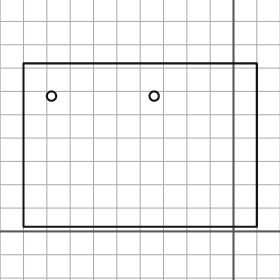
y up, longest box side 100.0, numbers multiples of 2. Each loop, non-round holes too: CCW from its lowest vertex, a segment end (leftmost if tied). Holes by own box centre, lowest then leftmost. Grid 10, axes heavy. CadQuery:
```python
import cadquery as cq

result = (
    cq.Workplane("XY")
    .moveTo(-90.0, 2.0)
    .lineTo(10.0, 2.0)
    .lineTo(10.0, 72.0)
    .lineTo(-90.0, 72.0)
    .close()
    .moveTo(-78.0, 58.0)
    .circle(2.0)
    .moveTo(-34.0, 58.0)
    .circle(2.0)
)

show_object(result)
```